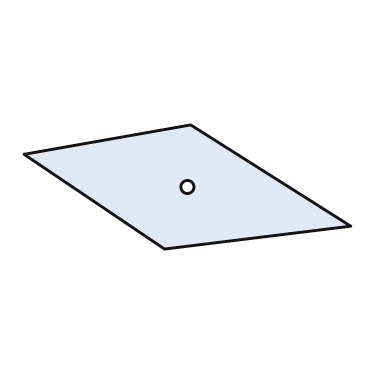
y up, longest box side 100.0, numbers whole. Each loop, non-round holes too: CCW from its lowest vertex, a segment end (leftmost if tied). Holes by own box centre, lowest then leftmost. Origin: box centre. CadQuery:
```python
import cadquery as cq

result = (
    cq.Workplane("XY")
    .moveTo(-7.0, -19.0)
    .lineTo(50.0, -12.0)
    .lineTo(1.0, 19.0)
    .lineTo(-50.0, 10.0)
    .close()
    .moveTo(0.0, 0.0)
    .circle(2.0)
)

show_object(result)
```